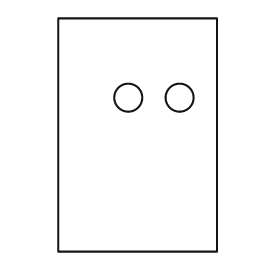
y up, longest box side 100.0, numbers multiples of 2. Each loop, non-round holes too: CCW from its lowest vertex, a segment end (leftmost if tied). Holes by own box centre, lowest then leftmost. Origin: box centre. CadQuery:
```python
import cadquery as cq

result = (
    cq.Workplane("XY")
    .moveTo(-34.0, -50.0)
    .lineTo(34.0, -50.0)
    .lineTo(34.0, 50.0)
    .lineTo(-34.0, 50.0)
    .close()
    .moveTo(-4.0, 16.0)
    .circle(6.0)
    .moveTo(18.0, 16.0)
    .circle(6.0)
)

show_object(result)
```